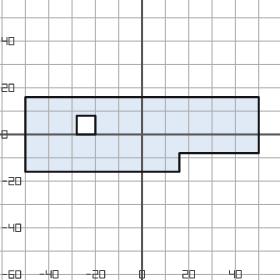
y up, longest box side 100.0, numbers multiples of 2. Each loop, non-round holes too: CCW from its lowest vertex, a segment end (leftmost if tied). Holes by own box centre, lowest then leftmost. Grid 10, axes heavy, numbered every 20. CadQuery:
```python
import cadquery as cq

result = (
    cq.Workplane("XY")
    .moveTo(-50.0, -16.0)
    .lineTo(16.0, -16.0)
    .lineTo(16.0, -8.0)
    .lineTo(50.0, -8.0)
    .lineTo(50.0, 16.0)
    .lineTo(-50.0, 16.0)
    .close()
    .moveTo(-28.0, 0.0)
    .lineTo(-20.0, 0.0)
    .lineTo(-20.0, 8.0)
    .lineTo(-28.0, 8.0)
    .close()
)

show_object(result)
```